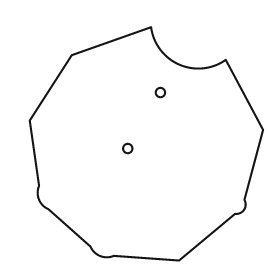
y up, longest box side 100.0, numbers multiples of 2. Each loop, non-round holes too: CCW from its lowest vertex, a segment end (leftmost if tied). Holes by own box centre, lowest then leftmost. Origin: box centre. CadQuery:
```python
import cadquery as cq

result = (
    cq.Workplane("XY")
    .moveTo(14.0, -50.0)
    .lineTo(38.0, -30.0)
    .threePointArc((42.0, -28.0), (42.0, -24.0))
    .lineTo(50.0, 6.0)
    .lineTo(34.0, 36.0)
    .threePointArc((14.0, 34.0), (2.0, 50.0))
    .lineTo(-32.0, 38.0)
    .lineTo(-50.0, 10.0)
    .lineTo(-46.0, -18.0)
    .threePointArc((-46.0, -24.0), (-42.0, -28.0))
    .lineTo(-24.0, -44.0)
    .threePointArc((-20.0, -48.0), (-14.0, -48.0))
    .close()
    .moveTo(-8.0, -2.0)
    .circle(2.0)
    .moveTo(6.0, 22.0)
    .circle(2.0)
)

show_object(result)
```